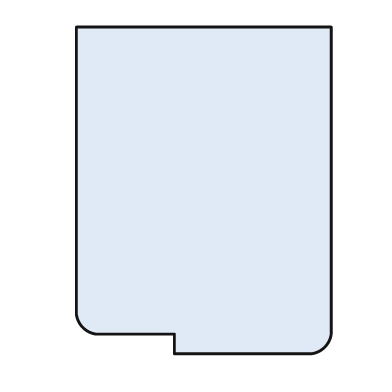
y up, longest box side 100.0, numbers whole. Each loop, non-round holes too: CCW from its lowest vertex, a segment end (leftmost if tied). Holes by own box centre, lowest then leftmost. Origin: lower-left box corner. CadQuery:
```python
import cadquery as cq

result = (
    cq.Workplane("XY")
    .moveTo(30.0, 0.0)
    .lineTo(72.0, 0.0)
    .threePointArc((76.0, 2.0), (78.0, 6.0))
    .lineTo(78.0, 100.0)
    .lineTo(0.0, 100.0)
    .lineTo(0.0, 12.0)
    .threePointArc((2.0, 8.0), (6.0, 6.0))
    .lineTo(30.0, 6.0)
    .close()
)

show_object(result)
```